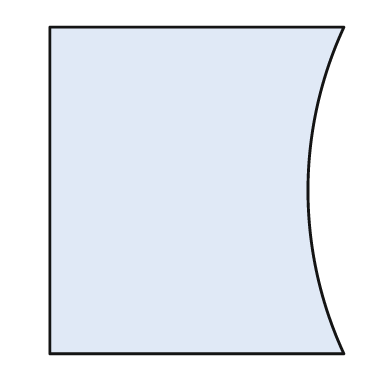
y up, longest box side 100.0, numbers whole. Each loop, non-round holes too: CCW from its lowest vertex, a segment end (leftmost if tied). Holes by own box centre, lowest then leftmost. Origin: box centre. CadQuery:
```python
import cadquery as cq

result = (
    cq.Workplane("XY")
    .moveTo(-45.0, -50.0)
    .lineTo(45.0, -50.0)
    .threePointArc((34.0, 0.0), (45.0, 50.0))
    .lineTo(-45.0, 50.0)
    .close()
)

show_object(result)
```